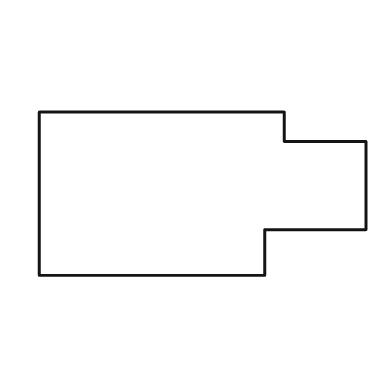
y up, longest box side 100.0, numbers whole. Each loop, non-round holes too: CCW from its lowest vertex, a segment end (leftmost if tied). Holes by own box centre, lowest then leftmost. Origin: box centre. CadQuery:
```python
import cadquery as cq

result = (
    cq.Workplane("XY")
    .moveTo(-50.0, -25.0)
    .lineTo(19.0, -25.0)
    .lineTo(19.0, -11.0)
    .lineTo(50.0, -11.0)
    .lineTo(50.0, 16.0)
    .lineTo(25.0, 16.0)
    .lineTo(25.0, 25.0)
    .lineTo(-50.0, 25.0)
    .close()
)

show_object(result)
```